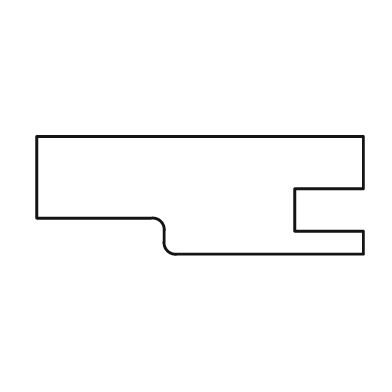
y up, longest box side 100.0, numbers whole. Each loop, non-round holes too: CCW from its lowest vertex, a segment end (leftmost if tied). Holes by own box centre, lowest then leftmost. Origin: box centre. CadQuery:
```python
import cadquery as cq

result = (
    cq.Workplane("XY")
    .moveTo(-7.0, -18.0)
    .lineTo(50.0, -18.0)
    .lineTo(50.0, -11.0)
    .lineTo(29.0, -11.0)
    .lineTo(29.0, 2.0)
    .lineTo(50.0, 2.0)
    .lineTo(50.0, 18.0)
    .lineTo(-50.0, 18.0)
    .lineTo(-50.0, -7.0)
    .lineTo(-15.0, -7.0)
    .threePointArc((-12.0, -8.0), (-11.0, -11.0))
    .lineTo(-11.0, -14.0)
    .threePointArc((-10.0, -17.0), (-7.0, -18.0))
    .close()
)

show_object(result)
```